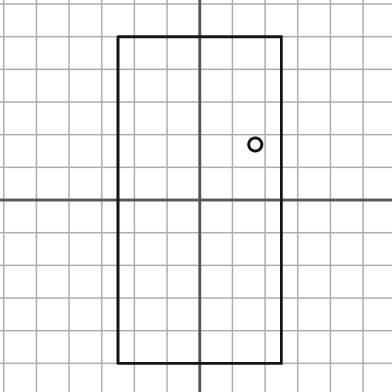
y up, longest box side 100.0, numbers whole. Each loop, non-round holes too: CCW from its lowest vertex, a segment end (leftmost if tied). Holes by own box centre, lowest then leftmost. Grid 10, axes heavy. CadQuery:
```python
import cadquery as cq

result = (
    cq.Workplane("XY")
    .moveTo(-25.0, -50.0)
    .lineTo(25.0, -50.0)
    .lineTo(25.0, 50.0)
    .lineTo(-25.0, 50.0)
    .close()
    .moveTo(17.0, 17.0)
    .circle(2.0)
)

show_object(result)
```